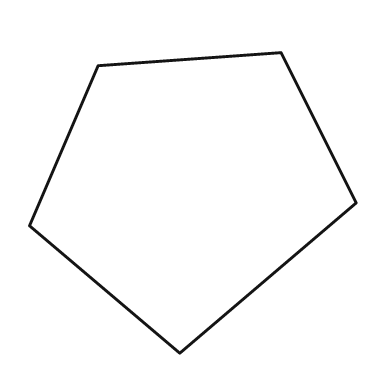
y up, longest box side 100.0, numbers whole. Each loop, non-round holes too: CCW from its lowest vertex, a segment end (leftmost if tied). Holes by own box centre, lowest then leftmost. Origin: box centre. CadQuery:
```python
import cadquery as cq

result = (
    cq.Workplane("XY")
    .moveTo(-4.0, -46.0)
    .lineTo(50.0, 0.0)
    .lineTo(27.0, 46.0)
    .lineTo(-29.0, 42.0)
    .lineTo(-50.0, -7.0)
    .close()
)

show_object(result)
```